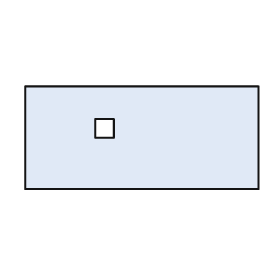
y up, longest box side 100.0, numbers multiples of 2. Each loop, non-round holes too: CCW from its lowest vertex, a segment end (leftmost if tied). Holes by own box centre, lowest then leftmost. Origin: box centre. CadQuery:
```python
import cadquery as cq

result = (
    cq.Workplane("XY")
    .moveTo(-50.0, -22.0)
    .lineTo(50.0, -22.0)
    .lineTo(50.0, 22.0)
    .lineTo(-50.0, 22.0)
    .close()
    .moveTo(-20.0, 0.0)
    .lineTo(-12.0, 0.0)
    .lineTo(-12.0, 8.0)
    .lineTo(-20.0, 8.0)
    .close()
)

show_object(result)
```